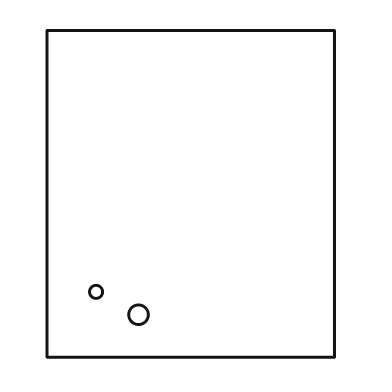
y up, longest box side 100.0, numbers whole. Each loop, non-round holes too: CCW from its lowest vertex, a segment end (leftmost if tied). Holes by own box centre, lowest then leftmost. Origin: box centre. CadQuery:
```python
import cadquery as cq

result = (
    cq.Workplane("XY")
    .moveTo(-44.0, -50.0)
    .lineTo(44.0, -50.0)
    .lineTo(44.0, 50.0)
    .lineTo(-44.0, 50.0)
    .close()
    .moveTo(-16.0, -37.0)
    .circle(3.0)
    .moveTo(-29.0, -30.0)
    .circle(2.0)
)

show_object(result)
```